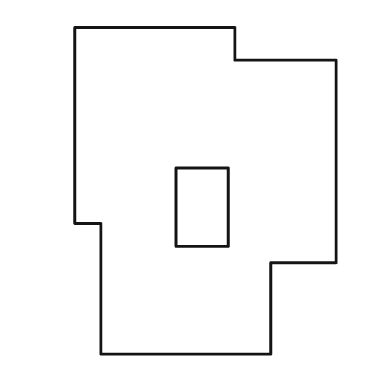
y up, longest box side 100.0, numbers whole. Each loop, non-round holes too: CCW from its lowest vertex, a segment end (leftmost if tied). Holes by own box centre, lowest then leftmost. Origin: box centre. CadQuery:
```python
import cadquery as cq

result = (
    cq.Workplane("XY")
    .moveTo(-32.0, -50.0)
    .lineTo(20.0, -50.0)
    .lineTo(20.0, -22.0)
    .lineTo(40.0, -22.0)
    .lineTo(40.0, 40.0)
    .lineTo(9.0, 40.0)
    .lineTo(9.0, 50.0)
    .lineTo(-40.0, 50.0)
    .lineTo(-40.0, -10.0)
    .lineTo(-32.0, -10.0)
    .close()
    .moveTo(-9.0, -17.0)
    .lineTo(7.0, -17.0)
    .lineTo(7.0, 7.0)
    .lineTo(-9.0, 7.0)
    .close()
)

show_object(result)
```